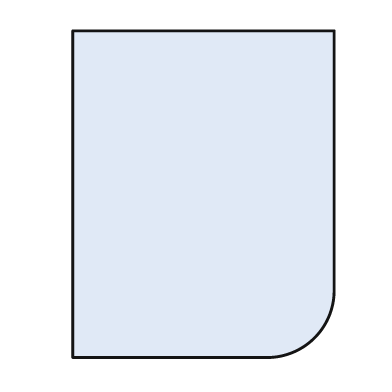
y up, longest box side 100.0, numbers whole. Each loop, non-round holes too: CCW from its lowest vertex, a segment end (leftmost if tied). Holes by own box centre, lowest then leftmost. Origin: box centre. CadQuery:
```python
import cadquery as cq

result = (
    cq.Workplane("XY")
    .moveTo(-40.0, -50.0)
    .lineTo(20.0, -50.0)
    .threePointArc((34.0, -44.0), (40.0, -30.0))
    .lineTo(40.0, 50.0)
    .lineTo(-40.0, 50.0)
    .close()
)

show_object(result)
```